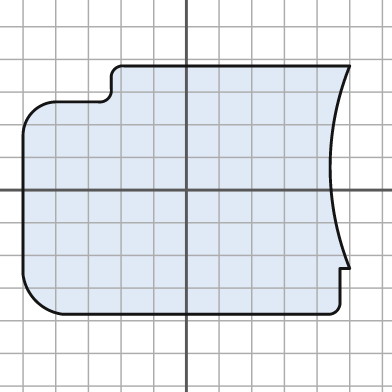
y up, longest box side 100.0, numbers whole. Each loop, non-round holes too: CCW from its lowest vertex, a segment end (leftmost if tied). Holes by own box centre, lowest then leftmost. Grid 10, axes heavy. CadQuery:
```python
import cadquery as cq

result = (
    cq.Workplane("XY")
    .moveTo(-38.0, -38.0)
    .lineTo(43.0, -38.0)
    .threePointArc((46.0, -37.0), (47.0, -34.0))
    .lineTo(47.0, -24.0)
    .lineTo(50.0, -24.0)
    .threePointArc((44.0, 7.0), (50.0, 38.0))
    .lineTo(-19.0, 38.0)
    .threePointArc((-22.0, 37.0), (-23.0, 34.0))
    .lineTo(-23.0, 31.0)
    .threePointArc((-24.0, 28.0), (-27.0, 27.0))
    .lineTo(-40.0, 27.0)
    .threePointArc((-47.0, 24.0), (-50.0, 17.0))
    .lineTo(-50.0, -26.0)
    .threePointArc((-46.0, -34.0), (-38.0, -38.0))
    .close()
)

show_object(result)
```